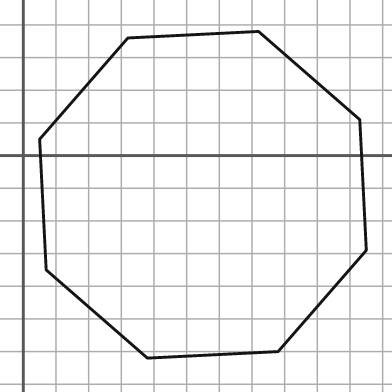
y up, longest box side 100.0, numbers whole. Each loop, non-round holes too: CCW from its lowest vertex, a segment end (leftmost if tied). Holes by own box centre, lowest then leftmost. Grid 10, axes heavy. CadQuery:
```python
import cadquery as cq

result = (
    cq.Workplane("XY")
    .moveTo(38.0, -62.0)
    .lineTo(78.0, -60.0)
    .lineTo(105.0, -29.0)
    .lineTo(103.0, 11.0)
    .lineTo(72.0, 38.0)
    .lineTo(32.0, 36.0)
    .lineTo(5.0, 5.0)
    .lineTo(7.0, -35.0)
    .close()
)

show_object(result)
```